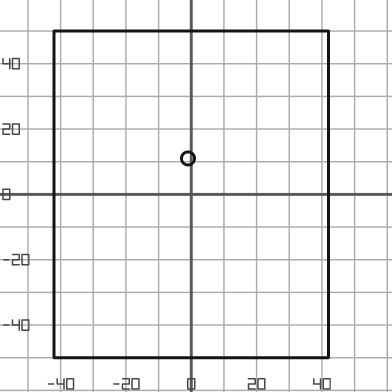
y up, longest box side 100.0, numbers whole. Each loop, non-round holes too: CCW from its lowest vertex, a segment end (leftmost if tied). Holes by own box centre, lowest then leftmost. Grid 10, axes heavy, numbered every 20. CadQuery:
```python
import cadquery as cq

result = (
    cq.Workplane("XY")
    .moveTo(-42.0, -50.0)
    .lineTo(42.0, -50.0)
    .lineTo(42.0, 50.0)
    .lineTo(-42.0, 50.0)
    .close()
    .moveTo(-1.0, 11.0)
    .circle(2.0)
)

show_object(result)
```